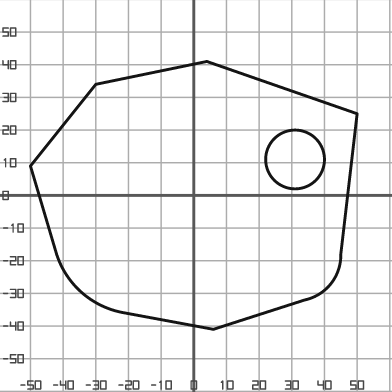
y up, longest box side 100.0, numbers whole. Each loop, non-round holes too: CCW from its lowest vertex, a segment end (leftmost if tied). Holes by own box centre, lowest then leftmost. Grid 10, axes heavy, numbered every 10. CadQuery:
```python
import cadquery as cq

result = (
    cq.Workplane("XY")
    .moveTo(6.0, -41.0)
    .lineTo(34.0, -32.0)
    .threePointArc((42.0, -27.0), (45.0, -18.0))
    .lineTo(50.0, 25.0)
    .lineTo(4.0, 41.0)
    .lineTo(-30.0, 34.0)
    .lineTo(-50.0, 9.0)
    .lineTo(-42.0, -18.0)
    .threePointArc((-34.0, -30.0), (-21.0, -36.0))
    .close()
    .moveTo(31.0, 11.0)
    .circle(9.0)
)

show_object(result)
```